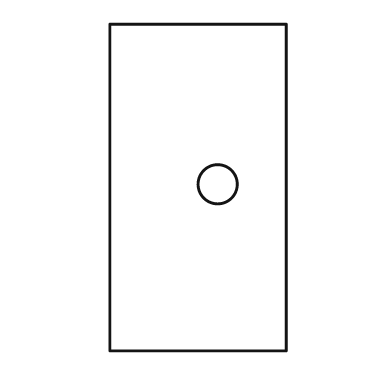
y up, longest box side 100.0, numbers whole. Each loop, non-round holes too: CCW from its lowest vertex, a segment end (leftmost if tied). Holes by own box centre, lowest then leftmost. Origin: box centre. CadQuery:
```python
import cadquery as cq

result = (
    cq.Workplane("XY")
    .moveTo(-27.0, -50.0)
    .lineTo(27.0, -50.0)
    .lineTo(27.0, 50.0)
    .lineTo(-27.0, 50.0)
    .close()
    .moveTo(6.0, 1.0)
    .circle(6.0)
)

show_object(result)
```